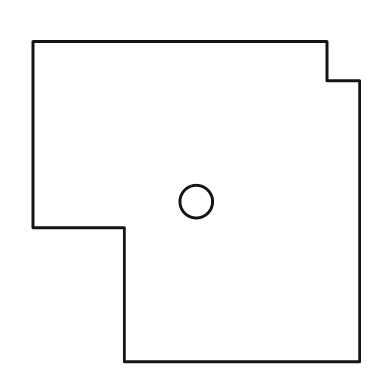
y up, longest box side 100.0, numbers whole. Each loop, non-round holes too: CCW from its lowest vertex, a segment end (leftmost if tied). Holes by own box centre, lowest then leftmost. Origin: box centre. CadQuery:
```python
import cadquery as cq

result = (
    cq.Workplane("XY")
    .moveTo(-22.0, -49.0)
    .lineTo(50.0, -49.0)
    .lineTo(50.0, 37.0)
    .lineTo(40.0, 37.0)
    .lineTo(40.0, 49.0)
    .lineTo(-50.0, 49.0)
    .lineTo(-50.0, -8.0)
    .lineTo(-22.0, -8.0)
    .close()
    .moveTo(0.0, 0.0)
    .circle(5.0)
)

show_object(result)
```